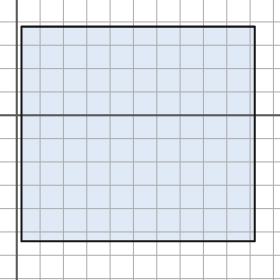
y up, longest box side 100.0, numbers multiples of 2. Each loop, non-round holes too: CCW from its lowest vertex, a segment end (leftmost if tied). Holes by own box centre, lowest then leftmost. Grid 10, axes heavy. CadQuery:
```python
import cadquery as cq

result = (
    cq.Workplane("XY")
    .moveTo(2.0, -54.0)
    .lineTo(102.0, -54.0)
    .lineTo(102.0, 38.0)
    .lineTo(2.0, 38.0)
    .close()
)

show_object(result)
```